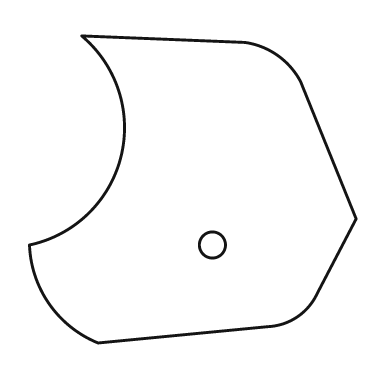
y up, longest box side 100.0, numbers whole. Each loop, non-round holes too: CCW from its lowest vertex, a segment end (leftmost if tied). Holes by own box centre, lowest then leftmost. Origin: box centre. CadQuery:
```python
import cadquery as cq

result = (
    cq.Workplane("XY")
    .moveTo(-29.0, -47.0)
    .lineTo(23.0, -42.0)
    .threePointArc((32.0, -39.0), (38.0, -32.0))
    .lineTo(50.0, -9.0)
    .lineTo(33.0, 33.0)
    .threePointArc((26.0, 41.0), (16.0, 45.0))
    .lineTo(-34.0, 47.0)
    .threePointArc((-22.0, 10.0), (-50.0, -17.0))
    .threePointArc((-44.0, -35.0), (-29.0, -47.0))
    .close()
    .moveTo(6.0, -17.0)
    .circle(4.0)
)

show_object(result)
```